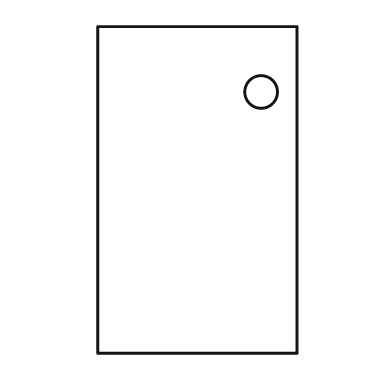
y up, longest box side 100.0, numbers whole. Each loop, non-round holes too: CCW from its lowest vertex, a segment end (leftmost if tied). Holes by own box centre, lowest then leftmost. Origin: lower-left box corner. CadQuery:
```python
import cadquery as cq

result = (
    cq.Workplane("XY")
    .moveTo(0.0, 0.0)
    .lineTo(61.0, 0.0)
    .lineTo(61.0, 100.0)
    .lineTo(0.0, 100.0)
    .close()
    .moveTo(50.0, 80.0)
    .circle(5.0)
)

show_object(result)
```